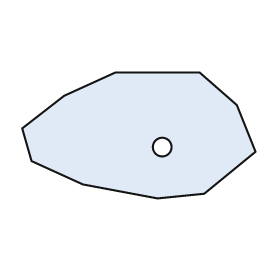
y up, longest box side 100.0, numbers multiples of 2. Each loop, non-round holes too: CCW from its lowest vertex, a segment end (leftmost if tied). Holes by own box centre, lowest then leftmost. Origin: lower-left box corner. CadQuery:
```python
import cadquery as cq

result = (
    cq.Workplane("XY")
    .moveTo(58.0, 0.0)
    .lineTo(78.0, 2.0)
    .lineTo(100.0, 20.0)
    .lineTo(92.0, 40.0)
    .lineTo(76.0, 54.0)
    .lineTo(40.0, 54.0)
    .lineTo(18.0, 44.0)
    .lineTo(0.0, 30.0)
    .lineTo(4.0, 16.0)
    .lineTo(26.0, 6.0)
    .close()
    .moveTo(60.0, 22.0)
    .circle(4.0)
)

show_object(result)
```